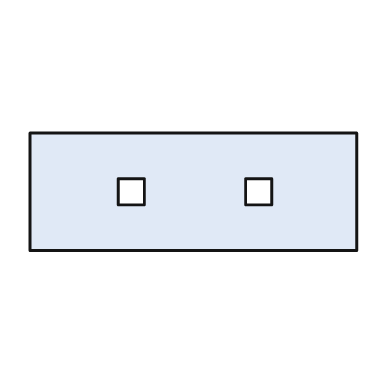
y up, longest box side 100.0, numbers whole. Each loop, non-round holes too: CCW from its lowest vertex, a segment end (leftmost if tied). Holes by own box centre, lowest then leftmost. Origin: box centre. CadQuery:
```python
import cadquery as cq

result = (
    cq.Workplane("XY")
    .moveTo(-50.0, -18.0)
    .lineTo(50.0, -18.0)
    .lineTo(50.0, 18.0)
    .lineTo(-50.0, 18.0)
    .close()
    .moveTo(-23.0, -4.0)
    .lineTo(-15.0, -4.0)
    .lineTo(-15.0, 4.0)
    .lineTo(-23.0, 4.0)
    .close()
    .moveTo(16.0, -4.0)
    .lineTo(24.0, -4.0)
    .lineTo(24.0, 4.0)
    .lineTo(16.0, 4.0)
    .close()
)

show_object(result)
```